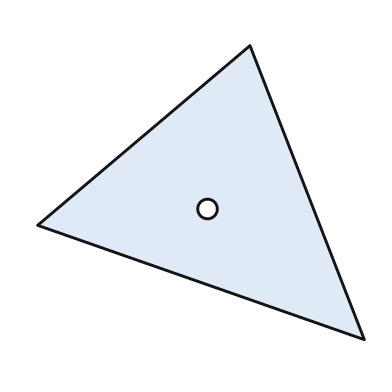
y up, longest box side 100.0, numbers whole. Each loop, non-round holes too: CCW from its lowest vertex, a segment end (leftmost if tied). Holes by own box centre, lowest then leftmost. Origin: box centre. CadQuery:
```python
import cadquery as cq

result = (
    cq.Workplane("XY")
    .moveTo(50.0, -45.0)
    .lineTo(15.0, 45.0)
    .lineTo(-50.0, -10.0)
    .close()
    .moveTo(2.0, -5.0)
    .circle(3.0)
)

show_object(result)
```